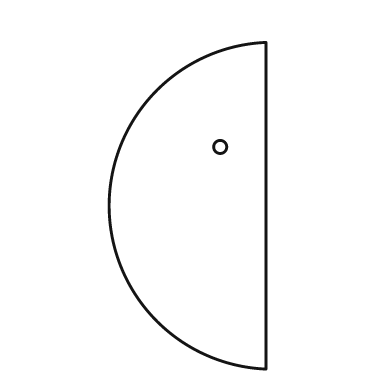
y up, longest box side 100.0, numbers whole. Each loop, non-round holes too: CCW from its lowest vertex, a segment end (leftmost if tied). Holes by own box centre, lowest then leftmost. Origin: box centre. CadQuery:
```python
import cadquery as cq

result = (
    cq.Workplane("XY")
    .moveTo(24.0, -50.0)
    .lineTo(24.0, 50.0)
    .threePointArc((-24.0, 0.0), (24.0, -50.0))
    .close()
    .moveTo(10.0, 18.0)
    .circle(2.0)
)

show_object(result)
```